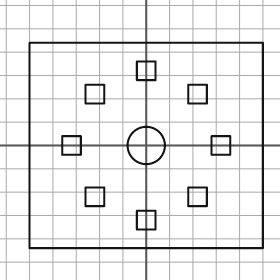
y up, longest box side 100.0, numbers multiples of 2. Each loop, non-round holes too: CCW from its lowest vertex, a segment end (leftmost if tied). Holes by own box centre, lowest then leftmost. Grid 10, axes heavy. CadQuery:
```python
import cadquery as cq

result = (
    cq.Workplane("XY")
    .moveTo(-50.0, -44.0)
    .lineTo(50.0, -44.0)
    .lineTo(50.0, 44.0)
    .lineTo(-50.0, 44.0)
    .close()
    .moveTo(-4.0, -36.0)
    .lineTo(4.0, -36.0)
    .lineTo(4.0, -28.0)
    .lineTo(-4.0, -28.0)
    .close()
    .moveTo(-26.0, -26.0)
    .lineTo(-18.0, -26.0)
    .lineTo(-18.0, -18.0)
    .lineTo(-26.0, -18.0)
    .close()
    .moveTo(18.0, -26.0)
    .lineTo(26.0, -26.0)
    .lineTo(26.0, -18.0)
    .lineTo(18.0, -18.0)
    .close()
    .moveTo(-36.0, -4.0)
    .lineTo(-28.0, -4.0)
    .lineTo(-28.0, 4.0)
    .lineTo(-36.0, 4.0)
    .close()
    .moveTo(0.0, 0.0)
    .circle(8.0)
    .moveTo(28.0, -4.0)
    .lineTo(36.0, -4.0)
    .lineTo(36.0, 4.0)
    .lineTo(28.0, 4.0)
    .close()
    .moveTo(-26.0, 18.0)
    .lineTo(-18.0, 18.0)
    .lineTo(-18.0, 26.0)
    .lineTo(-26.0, 26.0)
    .close()
    .moveTo(18.0, 18.0)
    .lineTo(26.0, 18.0)
    .lineTo(26.0, 26.0)
    .lineTo(18.0, 26.0)
    .close()
    .moveTo(-4.0, 28.0)
    .lineTo(4.0, 28.0)
    .lineTo(4.0, 36.0)
    .lineTo(-4.0, 36.0)
    .close()
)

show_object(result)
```